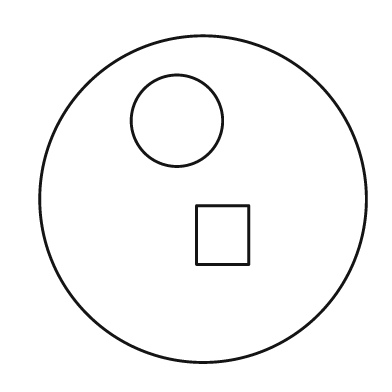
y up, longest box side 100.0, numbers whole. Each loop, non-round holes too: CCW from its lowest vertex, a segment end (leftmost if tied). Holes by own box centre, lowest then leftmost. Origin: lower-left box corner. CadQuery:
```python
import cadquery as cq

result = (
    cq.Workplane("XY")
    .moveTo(50.0, 50.0)
    .circle(50.0)
    .moveTo(48.0, 30.0)
    .lineTo(64.0, 30.0)
    .lineTo(64.0, 48.0)
    .lineTo(48.0, 48.0)
    .close()
    .moveTo(42.0, 74.0)
    .circle(14.0)
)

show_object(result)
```